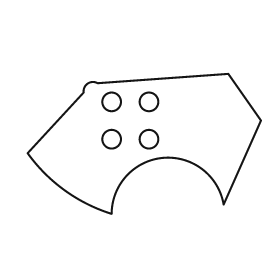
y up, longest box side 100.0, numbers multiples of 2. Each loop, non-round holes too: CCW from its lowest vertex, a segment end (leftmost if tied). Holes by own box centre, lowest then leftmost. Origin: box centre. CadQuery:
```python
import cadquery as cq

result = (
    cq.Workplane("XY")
    .moveTo(-14.0, -30.0)
    .threePointArc((8.0, -6.0), (34.0, -26.0))
    .lineTo(50.0, 10.0)
    .lineTo(36.0, 30.0)
    .lineTo(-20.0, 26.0)
    .threePointArc((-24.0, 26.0), (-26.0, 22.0))
    .lineTo(-50.0, -4.0)
    .threePointArc((-34.0, -20.0), (-14.0, -30.0))
    .close()
    .moveTo(-14.0, 2.0)
    .circle(4.0)
    .moveTo(2.0, 2.0)
    .circle(4.0)
    .moveTo(-14.0, 18.0)
    .circle(4.0)
    .moveTo(2.0, 18.0)
    .circle(4.0)
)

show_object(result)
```